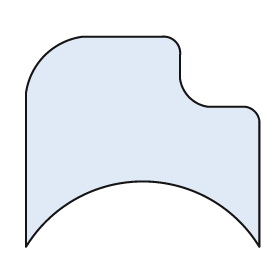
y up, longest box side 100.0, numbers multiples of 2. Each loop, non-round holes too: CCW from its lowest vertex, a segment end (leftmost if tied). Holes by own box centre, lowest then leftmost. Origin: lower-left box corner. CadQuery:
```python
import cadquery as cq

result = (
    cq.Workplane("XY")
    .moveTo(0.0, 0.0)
    .threePointArc((50.0, 28.0), (100.0, 0.0))
    .lineTo(100.0, 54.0)
    .threePointArc((98.0, 58.0), (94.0, 60.0))
    .lineTo(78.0, 60.0)
    .threePointArc((70.0, 64.0), (66.0, 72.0))
    .lineTo(66.0, 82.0)
    .threePointArc((64.0, 88.0), (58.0, 90.0))
    .lineTo(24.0, 90.0)
    .threePointArc((8.0, 82.0), (0.0, 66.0))
    .close()
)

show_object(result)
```